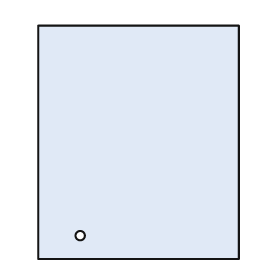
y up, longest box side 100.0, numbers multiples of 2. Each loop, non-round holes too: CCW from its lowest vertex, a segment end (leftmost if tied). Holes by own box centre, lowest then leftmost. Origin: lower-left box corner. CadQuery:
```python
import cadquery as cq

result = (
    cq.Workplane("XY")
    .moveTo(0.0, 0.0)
    .lineTo(86.0, 0.0)
    .lineTo(86.0, 100.0)
    .lineTo(0.0, 100.0)
    .close()
    .moveTo(18.0, 10.0)
    .circle(2.0)
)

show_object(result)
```